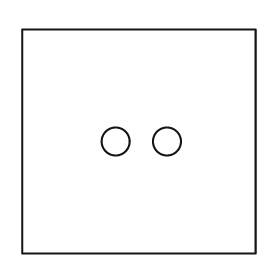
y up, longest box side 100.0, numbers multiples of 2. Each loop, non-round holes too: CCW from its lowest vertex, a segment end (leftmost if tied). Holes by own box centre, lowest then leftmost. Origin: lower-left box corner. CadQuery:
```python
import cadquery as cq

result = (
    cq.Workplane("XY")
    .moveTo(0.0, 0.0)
    .lineTo(100.0, 0.0)
    .lineTo(100.0, 96.0)
    .lineTo(0.0, 96.0)
    .close()
    .moveTo(40.0, 48.0)
    .circle(6.0)
    .moveTo(62.0, 48.0)
    .circle(6.0)
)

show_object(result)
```